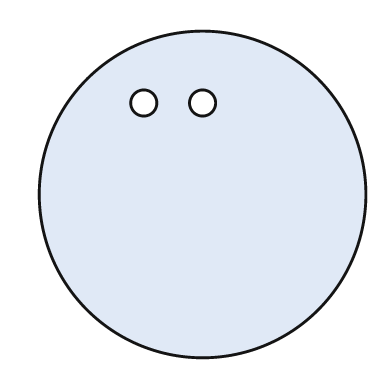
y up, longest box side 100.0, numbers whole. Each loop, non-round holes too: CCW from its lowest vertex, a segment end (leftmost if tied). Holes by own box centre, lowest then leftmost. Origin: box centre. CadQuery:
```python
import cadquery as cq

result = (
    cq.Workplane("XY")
    .moveTo(0.0, 0.0)
    .circle(50.0)
    .moveTo(-18.0, 28.0)
    .circle(4.0)
    .moveTo(0.0, 28.0)
    .circle(4.0)
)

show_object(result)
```